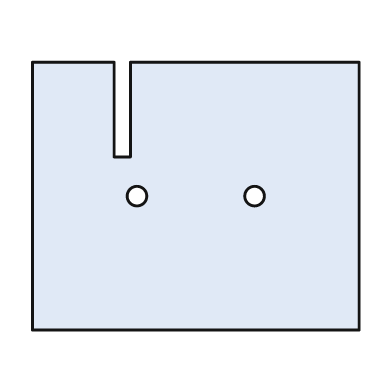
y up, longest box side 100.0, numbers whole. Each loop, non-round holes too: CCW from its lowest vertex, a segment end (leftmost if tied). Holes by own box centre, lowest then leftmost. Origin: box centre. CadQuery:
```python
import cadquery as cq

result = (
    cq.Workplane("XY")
    .moveTo(-50.0, -41.0)
    .lineTo(50.0, -41.0)
    .lineTo(50.0, 41.0)
    .lineTo(-20.0, 41.0)
    .lineTo(-20.0, 12.0)
    .lineTo(-25.0, 12.0)
    .lineTo(-25.0, 41.0)
    .lineTo(-50.0, 41.0)
    .close()
    .moveTo(-18.0, 0.0)
    .circle(3.0)
    .moveTo(18.0, 0.0)
    .circle(3.0)
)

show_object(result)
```